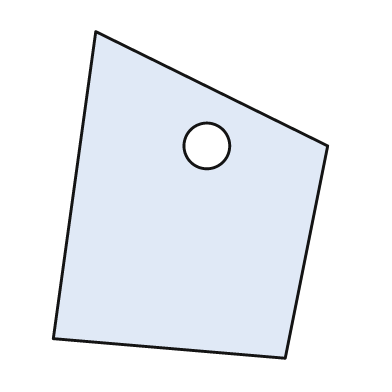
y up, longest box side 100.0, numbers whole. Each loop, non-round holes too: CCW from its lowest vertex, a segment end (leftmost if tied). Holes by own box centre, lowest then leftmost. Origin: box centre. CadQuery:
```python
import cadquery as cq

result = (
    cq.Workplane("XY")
    .moveTo(29.0, -50.0)
    .lineTo(42.0, 15.0)
    .lineTo(-29.0, 50.0)
    .lineTo(-42.0, -44.0)
    .close()
    .moveTo(5.0, 15.0)
    .circle(7.0)
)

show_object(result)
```